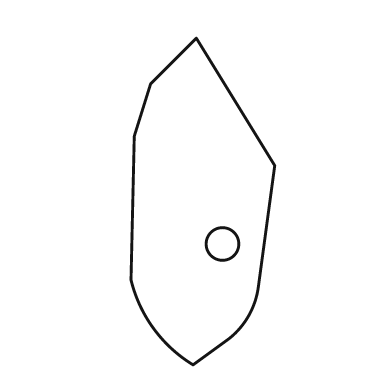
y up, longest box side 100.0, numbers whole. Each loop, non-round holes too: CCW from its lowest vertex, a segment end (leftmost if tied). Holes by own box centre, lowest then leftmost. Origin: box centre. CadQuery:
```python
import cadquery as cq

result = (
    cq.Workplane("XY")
    .moveTo(-3.0, -50.0)
    .lineTo(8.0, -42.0)
    .threePointArc((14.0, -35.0), (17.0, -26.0))
    .lineTo(22.0, 11.0)
    .lineTo(-2.0, 50.0)
    .lineTo(-16.0, 36.0)
    .lineTo(-21.0, 20.0)
    .lineTo(-22.0, -24.0)
    .threePointArc((-15.0, -39.0), (-3.0, -50.0))
    .close()
    .moveTo(6.0, -13.0)
    .circle(5.0)
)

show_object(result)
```